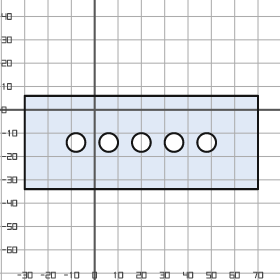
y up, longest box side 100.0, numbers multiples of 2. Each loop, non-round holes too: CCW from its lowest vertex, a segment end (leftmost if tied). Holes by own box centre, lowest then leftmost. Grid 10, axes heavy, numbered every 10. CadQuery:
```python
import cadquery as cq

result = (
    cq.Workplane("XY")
    .moveTo(-30.0, -34.0)
    .lineTo(70.0, -34.0)
    .lineTo(70.0, 6.0)
    .lineTo(-30.0, 6.0)
    .close()
    .moveTo(-8.0, -14.0)
    .circle(4.0)
    .moveTo(6.0, -14.0)
    .circle(4.0)
    .moveTo(20.0, -14.0)
    .circle(4.0)
    .moveTo(34.0, -14.0)
    .circle(4.0)
    .moveTo(48.0, -14.0)
    .circle(4.0)
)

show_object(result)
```